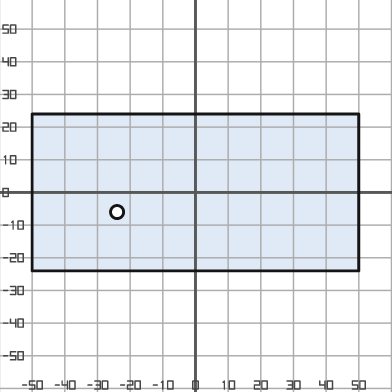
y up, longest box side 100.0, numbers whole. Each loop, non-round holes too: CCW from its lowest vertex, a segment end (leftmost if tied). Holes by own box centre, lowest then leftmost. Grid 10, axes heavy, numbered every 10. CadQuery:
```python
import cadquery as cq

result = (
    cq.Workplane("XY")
    .moveTo(-50.0, -24.0)
    .lineTo(50.0, -24.0)
    .lineTo(50.0, 24.0)
    .lineTo(-50.0, 24.0)
    .close()
    .moveTo(-24.0, -6.0)
    .circle(2.0)
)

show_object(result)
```